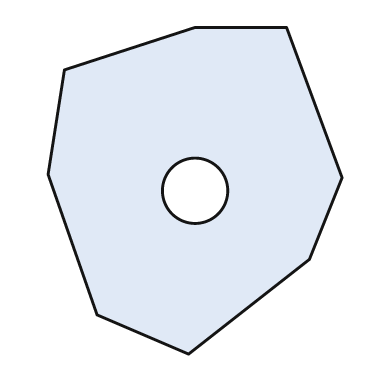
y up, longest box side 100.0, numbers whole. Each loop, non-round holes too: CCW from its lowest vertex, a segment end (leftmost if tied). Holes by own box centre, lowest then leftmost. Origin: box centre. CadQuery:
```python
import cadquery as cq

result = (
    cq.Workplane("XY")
    .moveTo(-2.0, -50.0)
    .lineTo(35.0, -21.0)
    .lineTo(45.0, 4.0)
    .lineTo(28.0, 50.0)
    .lineTo(0.0, 50.0)
    .lineTo(-40.0, 37.0)
    .lineTo(-45.0, 5.0)
    .lineTo(-30.0, -38.0)
    .close()
    .moveTo(0.0, 0.0)
    .circle(10.0)
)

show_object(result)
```